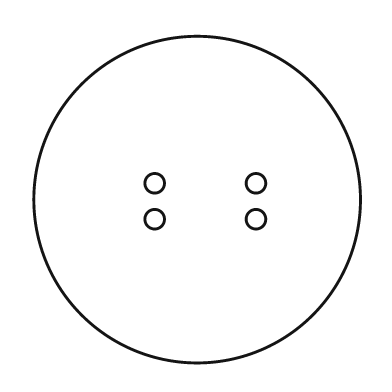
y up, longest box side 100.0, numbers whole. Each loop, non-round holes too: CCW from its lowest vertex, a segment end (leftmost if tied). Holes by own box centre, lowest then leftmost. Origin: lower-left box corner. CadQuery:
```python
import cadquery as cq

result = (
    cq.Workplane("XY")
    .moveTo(50.0, 50.0)
    .circle(50.0)
    .moveTo(37.0, 44.0)
    .circle(3.0)
    .moveTo(68.0, 44.0)
    .circle(3.0)
    .moveTo(37.0, 55.0)
    .circle(3.0)
    .moveTo(68.0, 55.0)
    .circle(3.0)
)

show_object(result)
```